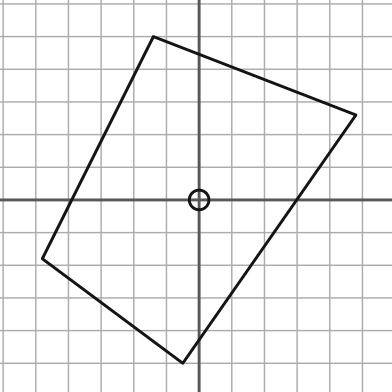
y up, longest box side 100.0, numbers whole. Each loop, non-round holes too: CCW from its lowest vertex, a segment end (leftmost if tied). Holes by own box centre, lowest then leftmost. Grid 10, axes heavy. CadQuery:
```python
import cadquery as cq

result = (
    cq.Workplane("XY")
    .moveTo(-5.0, -50.0)
    .lineTo(48.0, 26.0)
    .lineTo(-14.0, 50.0)
    .lineTo(-48.0, -18.0)
    .close()
    .moveTo(0.0, 0.0)
    .circle(3.0)
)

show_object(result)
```